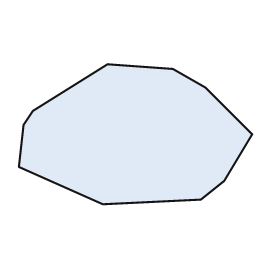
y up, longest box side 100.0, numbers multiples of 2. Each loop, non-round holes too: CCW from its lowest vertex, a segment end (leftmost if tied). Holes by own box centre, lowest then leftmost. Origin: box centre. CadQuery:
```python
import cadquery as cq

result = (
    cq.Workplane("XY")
    .moveTo(-14.0, -30.0)
    .lineTo(28.0, -28.0)
    .lineTo(38.0, -20.0)
    .lineTo(50.0, 0.0)
    .lineTo(30.0, 20.0)
    .lineTo(16.0, 28.0)
    .lineTo(-12.0, 30.0)
    .lineTo(-44.0, 10.0)
    .lineTo(-48.0, 4.0)
    .lineTo(-50.0, -14.0)
    .close()
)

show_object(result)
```